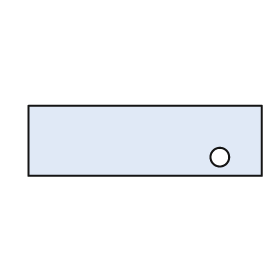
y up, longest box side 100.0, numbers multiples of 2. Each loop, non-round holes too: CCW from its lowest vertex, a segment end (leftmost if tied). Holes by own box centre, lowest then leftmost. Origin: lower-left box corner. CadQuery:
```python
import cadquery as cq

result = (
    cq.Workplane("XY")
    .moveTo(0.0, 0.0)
    .lineTo(100.0, 0.0)
    .lineTo(100.0, 30.0)
    .lineTo(0.0, 30.0)
    .close()
    .moveTo(82.0, 8.0)
    .circle(4.0)
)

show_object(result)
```